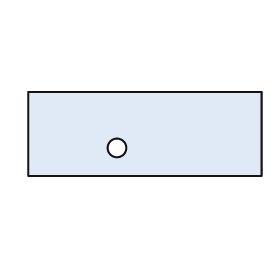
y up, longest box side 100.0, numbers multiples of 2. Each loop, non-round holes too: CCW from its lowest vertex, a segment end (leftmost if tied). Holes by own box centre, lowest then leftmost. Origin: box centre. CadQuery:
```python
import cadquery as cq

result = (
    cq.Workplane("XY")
    .moveTo(-50.0, -18.0)
    .lineTo(50.0, -18.0)
    .lineTo(50.0, 18.0)
    .lineTo(-50.0, 18.0)
    .close()
    .moveTo(-12.0, -6.0)
    .circle(4.0)
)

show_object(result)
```